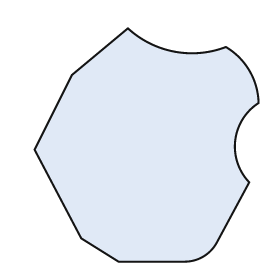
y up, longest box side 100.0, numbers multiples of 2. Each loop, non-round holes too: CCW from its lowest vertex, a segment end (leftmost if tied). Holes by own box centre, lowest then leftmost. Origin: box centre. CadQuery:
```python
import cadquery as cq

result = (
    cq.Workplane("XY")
    .moveTo(-12.0, -50.0)
    .lineTo(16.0, -50.0)
    .threePointArc((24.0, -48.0), (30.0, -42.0))
    .lineTo(44.0, -16.0)
    .threePointArc((38.0, 2.0), (48.0, 18.0))
    .threePointArc((44.0, 32.0), (34.0, 42.0))
    .threePointArc((12.0, 40.0), (-8.0, 50.0))
    .lineTo(-32.0, 30.0)
    .lineTo(-48.0, -2.0)
    .lineTo(-28.0, -40.0)
    .close()
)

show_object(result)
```